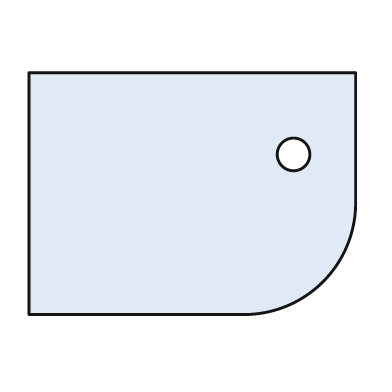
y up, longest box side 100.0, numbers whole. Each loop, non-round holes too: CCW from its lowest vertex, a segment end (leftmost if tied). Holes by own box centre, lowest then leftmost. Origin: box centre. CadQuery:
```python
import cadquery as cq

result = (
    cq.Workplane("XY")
    .moveTo(-50.0, -37.0)
    .lineTo(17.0, -37.0)
    .threePointArc((40.0, -27.0), (50.0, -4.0))
    .lineTo(50.0, 37.0)
    .lineTo(-50.0, 37.0)
    .close()
    .moveTo(31.0, 12.0)
    .circle(5.0)
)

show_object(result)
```